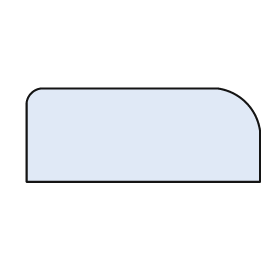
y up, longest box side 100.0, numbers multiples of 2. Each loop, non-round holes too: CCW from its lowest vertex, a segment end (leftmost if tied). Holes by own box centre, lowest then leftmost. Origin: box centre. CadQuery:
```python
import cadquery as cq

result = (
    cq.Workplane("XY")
    .moveTo(-50.0, -20.0)
    .lineTo(50.0, -20.0)
    .lineTo(50.0, 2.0)
    .threePointArc((44.0, 14.0), (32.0, 20.0))
    .lineTo(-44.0, 20.0)
    .threePointArc((-48.0, 18.0), (-50.0, 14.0))
    .close()
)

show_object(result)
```